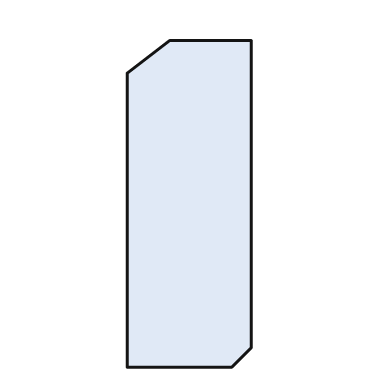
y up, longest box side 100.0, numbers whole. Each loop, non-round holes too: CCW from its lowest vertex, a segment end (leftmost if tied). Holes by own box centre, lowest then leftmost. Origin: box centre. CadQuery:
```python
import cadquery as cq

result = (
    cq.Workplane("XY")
    .moveTo(-19.0, -50.0)
    .lineTo(13.0, -50.0)
    .lineTo(19.0, -44.0)
    .lineTo(19.0, 50.0)
    .lineTo(-6.0, 50.0)
    .lineTo(-19.0, 40.0)
    .close()
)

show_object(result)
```